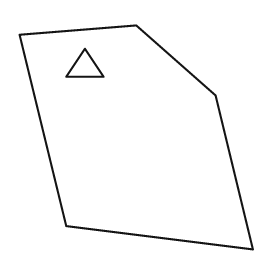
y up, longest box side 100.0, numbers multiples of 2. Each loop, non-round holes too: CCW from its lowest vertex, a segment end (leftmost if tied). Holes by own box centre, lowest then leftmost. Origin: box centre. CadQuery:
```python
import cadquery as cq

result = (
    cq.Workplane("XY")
    .moveTo(50.0, -48.0)
    .lineTo(34.0, 18.0)
    .lineTo(0.0, 48.0)
    .lineTo(-50.0, 44.0)
    .lineTo(-30.0, -38.0)
    .close()
    .moveTo(-30.0, 26.0)
    .lineTo(-14.0, 26.0)
    .lineTo(-22.0, 38.0)
    .close()
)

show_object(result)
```